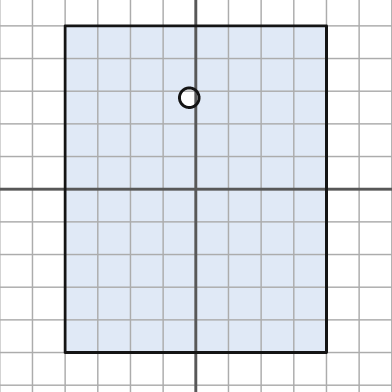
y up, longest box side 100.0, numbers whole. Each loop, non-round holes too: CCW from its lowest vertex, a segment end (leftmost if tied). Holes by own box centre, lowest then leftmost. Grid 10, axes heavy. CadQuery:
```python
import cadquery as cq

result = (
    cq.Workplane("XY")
    .moveTo(-40.0, -50.0)
    .lineTo(40.0, -50.0)
    .lineTo(40.0, 50.0)
    .lineTo(-40.0, 50.0)
    .close()
    .moveTo(-2.0, 28.0)
    .circle(3.0)
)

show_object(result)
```